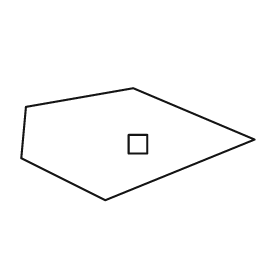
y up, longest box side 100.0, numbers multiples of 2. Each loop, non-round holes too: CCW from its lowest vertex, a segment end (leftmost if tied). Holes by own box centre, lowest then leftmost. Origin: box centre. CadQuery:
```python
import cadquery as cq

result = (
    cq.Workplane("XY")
    .moveTo(-14.0, -24.0)
    .lineTo(50.0, 2.0)
    .lineTo(-2.0, 24.0)
    .lineTo(-48.0, 16.0)
    .lineTo(-50.0, -6.0)
    .close()
    .moveTo(-4.0, -4.0)
    .lineTo(4.0, -4.0)
    .lineTo(4.0, 4.0)
    .lineTo(-4.0, 4.0)
    .close()
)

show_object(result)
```